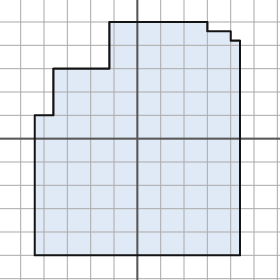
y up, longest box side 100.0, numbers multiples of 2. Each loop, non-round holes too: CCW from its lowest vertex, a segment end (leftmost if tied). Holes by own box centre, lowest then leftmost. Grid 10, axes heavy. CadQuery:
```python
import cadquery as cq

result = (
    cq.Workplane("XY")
    .moveTo(-44.0, -50.0)
    .lineTo(44.0, -50.0)
    .lineTo(44.0, 42.0)
    .lineTo(40.0, 42.0)
    .lineTo(40.0, 46.0)
    .lineTo(30.0, 46.0)
    .lineTo(30.0, 50.0)
    .lineTo(-12.0, 50.0)
    .lineTo(-12.0, 30.0)
    .lineTo(-36.0, 30.0)
    .lineTo(-36.0, 10.0)
    .lineTo(-44.0, 10.0)
    .close()
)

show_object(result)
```